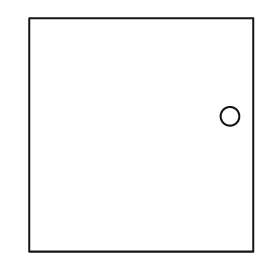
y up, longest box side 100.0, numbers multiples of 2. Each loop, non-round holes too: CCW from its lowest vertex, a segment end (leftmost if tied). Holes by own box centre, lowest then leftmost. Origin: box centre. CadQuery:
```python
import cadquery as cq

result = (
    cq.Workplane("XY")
    .moveTo(-48.0, -50.0)
    .lineTo(48.0, -50.0)
    .lineTo(48.0, 50.0)
    .lineTo(-48.0, 50.0)
    .close()
    .moveTo(38.0, 8.0)
    .circle(4.0)
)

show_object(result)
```